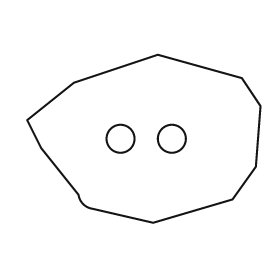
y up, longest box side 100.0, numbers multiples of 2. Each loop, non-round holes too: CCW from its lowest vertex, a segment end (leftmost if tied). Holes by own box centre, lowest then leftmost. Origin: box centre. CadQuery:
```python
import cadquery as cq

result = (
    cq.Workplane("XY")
    .moveTo(4.0, -36.0)
    .lineTo(38.0, -26.0)
    .lineTo(48.0, -12.0)
    .lineTo(50.0, 14.0)
    .lineTo(42.0, 26.0)
    .lineTo(6.0, 36.0)
    .lineTo(-30.0, 24.0)
    .lineTo(-50.0, 8.0)
    .lineTo(-44.0, -4.0)
    .lineTo(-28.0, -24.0)
    .threePointArc((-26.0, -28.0), (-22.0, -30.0))
    .close()
    .moveTo(-10.0, 0.0)
    .circle(6.0)
    .moveTo(12.0, 0.0)
    .circle(6.0)
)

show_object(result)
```